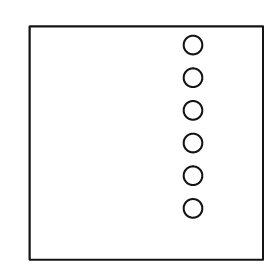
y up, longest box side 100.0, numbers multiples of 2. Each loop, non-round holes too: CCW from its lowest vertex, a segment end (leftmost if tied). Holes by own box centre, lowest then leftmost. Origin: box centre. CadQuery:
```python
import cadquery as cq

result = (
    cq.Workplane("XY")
    .moveTo(-50.0, -50.0)
    .lineTo(50.0, -50.0)
    .lineTo(50.0, 50.0)
    .lineTo(-50.0, 50.0)
    .close()
    .moveTo(20.0, -28.0)
    .circle(4.0)
    .moveTo(20.0, -14.0)
    .circle(4.0)
    .moveTo(20.0, 0.0)
    .circle(4.0)
    .moveTo(20.0, 14.0)
    .circle(4.0)
    .moveTo(20.0, 28.0)
    .circle(4.0)
    .moveTo(20.0, 42.0)
    .circle(4.0)
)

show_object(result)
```